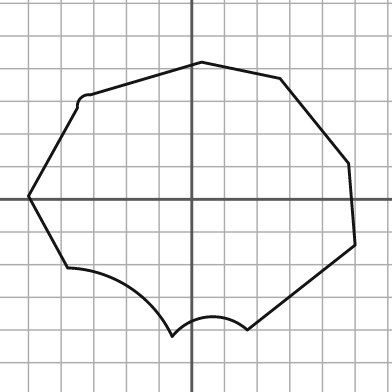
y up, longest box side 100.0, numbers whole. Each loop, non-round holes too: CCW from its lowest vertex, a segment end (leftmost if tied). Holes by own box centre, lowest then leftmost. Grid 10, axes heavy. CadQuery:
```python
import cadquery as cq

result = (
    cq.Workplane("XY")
    .moveTo(-6.0, -42.0)
    .threePointArc((5.0, -36.0), (17.0, -40.0))
    .lineTo(50.0, -14.0)
    .lineTo(48.0, 11.0)
    .lineTo(27.0, 37.0)
    .lineTo(3.0, 42.0)
    .lineTo(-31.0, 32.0)
    .threePointArc((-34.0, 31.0), (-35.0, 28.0))
    .lineTo(-50.0, 1.0)
    .lineTo(-38.0, -21.0)
    .threePointArc((-19.0, -27.0), (-6.0, -42.0))
    .close()
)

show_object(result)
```